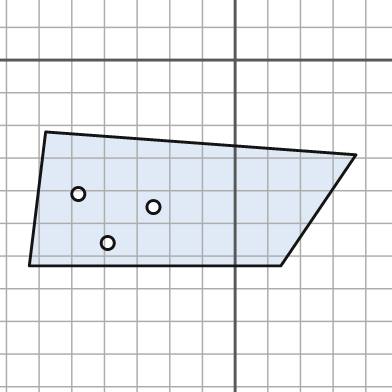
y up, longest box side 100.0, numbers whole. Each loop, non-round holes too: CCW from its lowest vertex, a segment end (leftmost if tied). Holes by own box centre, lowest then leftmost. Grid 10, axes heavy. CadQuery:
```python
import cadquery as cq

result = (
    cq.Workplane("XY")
    .moveTo(-63.0, -63.0)
    .lineTo(14.0, -63.0)
    .lineTo(37.0, -29.0)
    .lineTo(-58.0, -22.0)
    .close()
    .moveTo(-39.0, -56.0)
    .circle(2.0)
    .moveTo(-25.0, -45.0)
    .circle(2.0)
    .moveTo(-48.0, -41.0)
    .circle(2.0)
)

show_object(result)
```